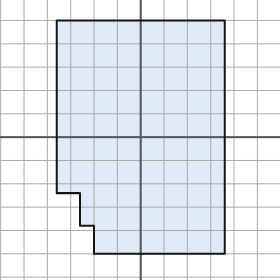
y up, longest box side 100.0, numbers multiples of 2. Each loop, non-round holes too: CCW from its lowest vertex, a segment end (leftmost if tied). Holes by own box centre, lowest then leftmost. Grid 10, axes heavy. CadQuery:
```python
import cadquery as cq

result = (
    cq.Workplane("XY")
    .moveTo(-20.0, -50.0)
    .lineTo(36.0, -50.0)
    .lineTo(36.0, 50.0)
    .lineTo(-36.0, 50.0)
    .lineTo(-36.0, -24.0)
    .lineTo(-26.0, -24.0)
    .lineTo(-26.0, -38.0)
    .lineTo(-20.0, -38.0)
    .close()
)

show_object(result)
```